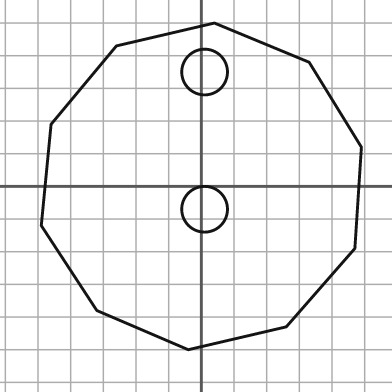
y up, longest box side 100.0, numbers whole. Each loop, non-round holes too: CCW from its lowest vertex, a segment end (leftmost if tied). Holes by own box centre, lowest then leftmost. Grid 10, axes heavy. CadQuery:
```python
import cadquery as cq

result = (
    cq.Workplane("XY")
    .moveTo(-4.0, -50.0)
    .lineTo(26.0, -43.0)
    .lineTo(47.0, -19.0)
    .lineTo(49.0, 12.0)
    .lineTo(33.0, 38.0)
    .lineTo(4.0, 50.0)
    .lineTo(-26.0, 43.0)
    .lineTo(-46.0, 19.0)
    .lineTo(-49.0, -12.0)
    .lineTo(-32.0, -38.0)
    .close()
    .moveTo(1.0, -7.0)
    .circle(7.0)
    .moveTo(1.0, 35.0)
    .circle(7.0)
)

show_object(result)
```